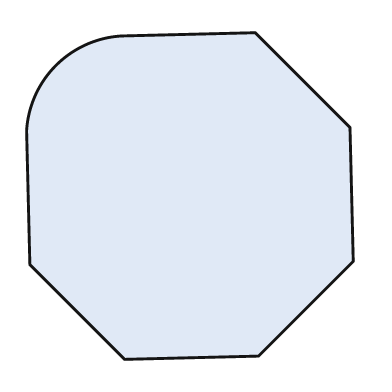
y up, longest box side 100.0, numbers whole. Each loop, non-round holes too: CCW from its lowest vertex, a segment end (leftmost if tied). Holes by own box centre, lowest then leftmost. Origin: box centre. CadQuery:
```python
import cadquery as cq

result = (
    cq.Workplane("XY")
    .moveTo(-20.0, -50.0)
    .lineTo(21.0, -49.0)
    .lineTo(50.0, -20.0)
    .lineTo(49.0, 21.0)
    .lineTo(20.0, 50.0)
    .lineTo(-21.0, 49.0)
    .threePointArc((-41.0, 40.0), (-50.0, 20.0))
    .lineTo(-49.0, -21.0)
    .close()
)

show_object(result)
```